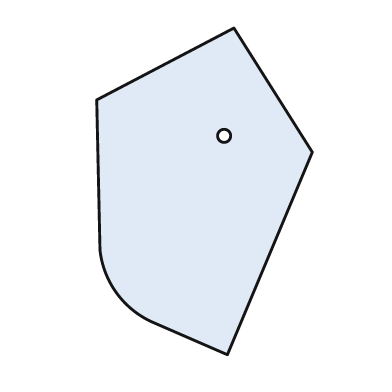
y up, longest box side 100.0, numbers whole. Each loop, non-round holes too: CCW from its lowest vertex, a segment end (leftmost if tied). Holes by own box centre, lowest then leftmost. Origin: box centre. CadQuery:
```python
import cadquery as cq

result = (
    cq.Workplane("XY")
    .moveTo(7.0, -50.0)
    .lineTo(33.0, 12.0)
    .lineTo(9.0, 50.0)
    .lineTo(-33.0, 28.0)
    .lineTo(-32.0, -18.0)
    .threePointArc((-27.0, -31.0), (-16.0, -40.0))
    .close()
    .moveTo(6.0, 17.0)
    .circle(2.0)
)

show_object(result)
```